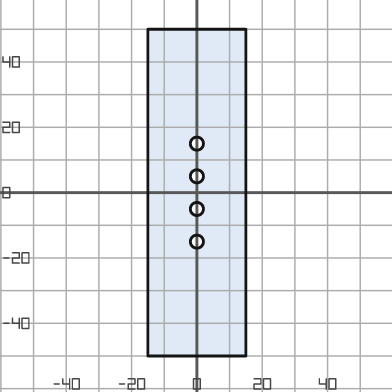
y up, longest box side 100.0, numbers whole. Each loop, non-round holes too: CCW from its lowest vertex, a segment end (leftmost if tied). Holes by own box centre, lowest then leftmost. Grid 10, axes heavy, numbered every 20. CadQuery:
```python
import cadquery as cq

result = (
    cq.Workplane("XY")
    .moveTo(-15.0, -50.0)
    .lineTo(15.0, -50.0)
    .lineTo(15.0, 50.0)
    .lineTo(-15.0, 50.0)
    .close()
    .moveTo(0.0, -15.0)
    .circle(2.0)
    .moveTo(0.0, -5.0)
    .circle(2.0)
    .moveTo(0.0, 5.0)
    .circle(2.0)
    .moveTo(0.0, 15.0)
    .circle(2.0)
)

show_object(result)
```